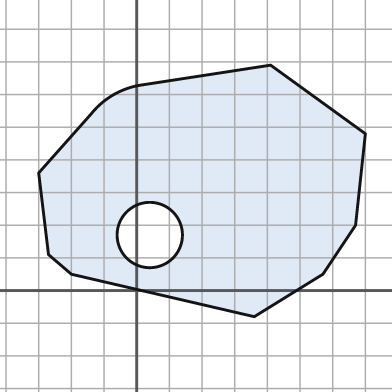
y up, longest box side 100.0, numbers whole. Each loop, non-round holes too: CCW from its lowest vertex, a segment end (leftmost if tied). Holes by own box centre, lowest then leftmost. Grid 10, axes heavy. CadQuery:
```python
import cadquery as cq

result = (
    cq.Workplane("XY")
    .moveTo(36.0, -8.0)
    .lineTo(57.0, 5.0)
    .lineTo(67.0, 20.0)
    .lineTo(70.0, 48.0)
    .lineTo(41.0, 69.0)
    .lineTo(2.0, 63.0)
    .threePointArc((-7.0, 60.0), (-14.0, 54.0))
    .lineTo(-30.0, 36.0)
    .lineTo(-27.0, 11.0)
    .lineTo(-20.0, 5.0)
    .close()
    .moveTo(4.0, 17.0)
    .circle(10.0)
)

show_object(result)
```